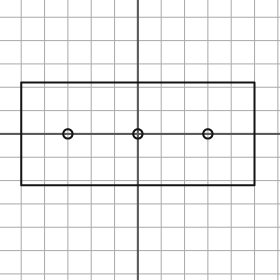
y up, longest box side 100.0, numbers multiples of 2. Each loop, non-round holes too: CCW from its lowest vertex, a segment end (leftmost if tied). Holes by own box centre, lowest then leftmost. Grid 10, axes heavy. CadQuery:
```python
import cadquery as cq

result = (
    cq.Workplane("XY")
    .moveTo(-50.0, -22.0)
    .lineTo(50.0, -22.0)
    .lineTo(50.0, 22.0)
    .lineTo(-50.0, 22.0)
    .close()
    .moveTo(-30.0, 0.0)
    .circle(2.0)
    .moveTo(0.0, 0.0)
    .circle(2.0)
    .moveTo(30.0, 0.0)
    .circle(2.0)
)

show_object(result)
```